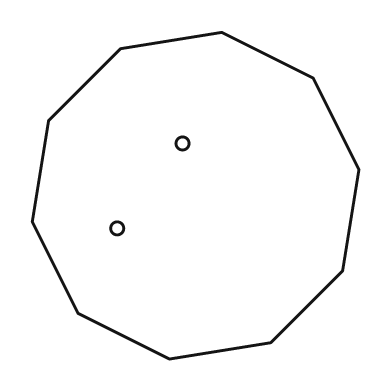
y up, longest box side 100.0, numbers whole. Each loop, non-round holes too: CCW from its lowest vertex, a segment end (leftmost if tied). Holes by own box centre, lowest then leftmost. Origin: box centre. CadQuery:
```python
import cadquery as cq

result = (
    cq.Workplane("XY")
    .moveTo(-8.0, -50.0)
    .lineTo(23.0, -45.0)
    .lineTo(45.0, -23.0)
    .lineTo(50.0, 8.0)
    .lineTo(36.0, 36.0)
    .lineTo(8.0, 50.0)
    .lineTo(-23.0, 45.0)
    .lineTo(-45.0, 23.0)
    .lineTo(-50.0, -8.0)
    .lineTo(-36.0, -36.0)
    .close()
    .moveTo(-24.0, -10.0)
    .circle(2.0)
    .moveTo(-4.0, 16.0)
    .circle(2.0)
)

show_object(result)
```